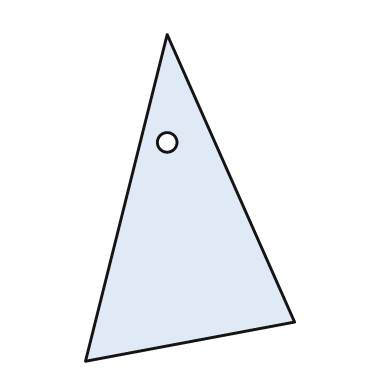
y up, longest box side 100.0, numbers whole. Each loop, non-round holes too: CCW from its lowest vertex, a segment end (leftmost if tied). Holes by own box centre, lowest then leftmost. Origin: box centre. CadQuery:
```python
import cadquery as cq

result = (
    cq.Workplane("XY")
    .moveTo(-32.0, -50.0)
    .lineTo(32.0, -38.0)
    .lineTo(-7.0, 50.0)
    .close()
    .moveTo(-7.0, 17.0)
    .circle(3.0)
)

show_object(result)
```